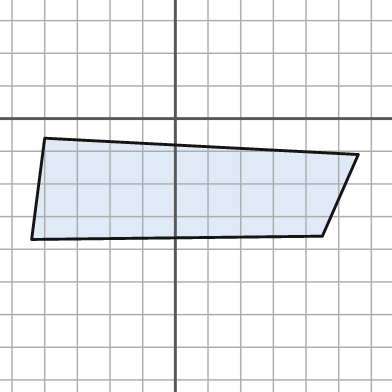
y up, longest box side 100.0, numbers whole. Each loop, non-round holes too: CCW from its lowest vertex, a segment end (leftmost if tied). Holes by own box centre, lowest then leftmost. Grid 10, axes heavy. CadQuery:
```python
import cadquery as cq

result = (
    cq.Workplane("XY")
    .moveTo(-44.0, -37.0)
    .lineTo(45.0, -36.0)
    .lineTo(56.0, -11.0)
    .lineTo(-40.0, -6.0)
    .close()
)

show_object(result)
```